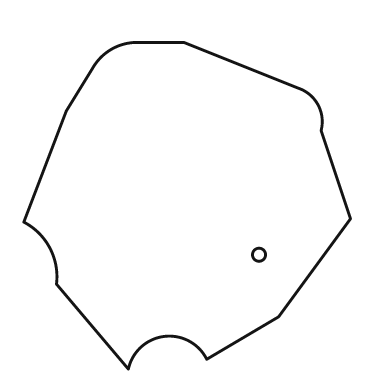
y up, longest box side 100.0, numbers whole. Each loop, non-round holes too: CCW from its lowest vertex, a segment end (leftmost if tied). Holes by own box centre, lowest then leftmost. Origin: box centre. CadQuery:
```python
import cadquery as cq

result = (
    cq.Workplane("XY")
    .moveTo(-18.0, -50.0)
    .threePointArc((-7.0, -40.0), (6.0, -47.0))
    .lineTo(28.0, -34.0)
    .lineTo(50.0, -4.0)
    .lineTo(41.0, 23.0)
    .threePointArc((40.0, 31.0), (34.0, 36.0))
    .lineTo(-1.0, 50.0)
    .lineTo(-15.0, 50.0)
    .threePointArc((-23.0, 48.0), (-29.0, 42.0))
    .lineTo(-37.0, 29.0)
    .lineTo(-50.0, -5.0)
    .threePointArc((-42.0, -13.0), (-40.0, -24.0))
    .close()
    .moveTo(22.0, -15.0)
    .circle(2.0)
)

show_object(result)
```